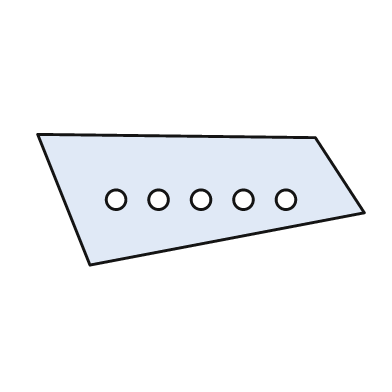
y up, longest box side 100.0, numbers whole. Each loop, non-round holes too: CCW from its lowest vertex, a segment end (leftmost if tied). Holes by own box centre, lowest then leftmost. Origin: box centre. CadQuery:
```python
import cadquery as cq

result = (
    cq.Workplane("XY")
    .moveTo(-34.0, -20.0)
    .lineTo(50.0, -4.0)
    .lineTo(35.0, 19.0)
    .lineTo(-50.0, 20.0)
    .close()
    .moveTo(-26.0, 0.0)
    .circle(3.0)
    .moveTo(-13.0, 0.0)
    .circle(3.0)
    .moveTo(0.0, 0.0)
    .circle(3.0)
    .moveTo(13.0, 0.0)
    .circle(3.0)
    .moveTo(26.0, 0.0)
    .circle(3.0)
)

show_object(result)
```